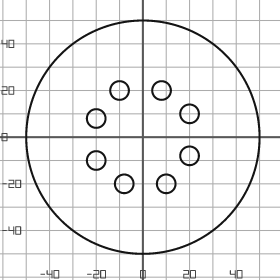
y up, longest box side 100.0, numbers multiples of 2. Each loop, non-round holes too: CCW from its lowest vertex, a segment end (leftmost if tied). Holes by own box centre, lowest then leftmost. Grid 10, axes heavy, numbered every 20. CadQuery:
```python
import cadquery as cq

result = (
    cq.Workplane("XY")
    .moveTo(0.0, 0.0)
    .circle(50.0)
    .moveTo(-8.0, -20.0)
    .circle(4.0)
    .moveTo(10.0, -20.0)
    .circle(4.0)
    .moveTo(-20.0, -10.0)
    .circle(4.0)
    .moveTo(20.0, -8.0)
    .circle(4.0)
    .moveTo(-20.0, 8.0)
    .circle(4.0)
    .moveTo(20.0, 10.0)
    .circle(4.0)
    .moveTo(-10.0, 20.0)
    .circle(4.0)
    .moveTo(8.0, 20.0)
    .circle(4.0)
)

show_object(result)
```